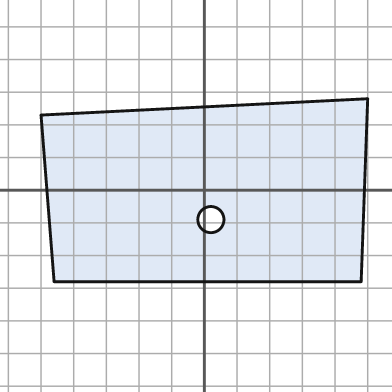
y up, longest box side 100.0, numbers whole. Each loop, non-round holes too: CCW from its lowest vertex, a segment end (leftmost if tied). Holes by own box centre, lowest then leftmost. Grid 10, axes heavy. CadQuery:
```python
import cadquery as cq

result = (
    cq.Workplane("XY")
    .moveTo(-46.0, -28.0)
    .lineTo(48.0, -28.0)
    .lineTo(50.0, 28.0)
    .lineTo(-50.0, 23.0)
    .close()
    .moveTo(2.0, -9.0)
    .circle(4.0)
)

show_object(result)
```